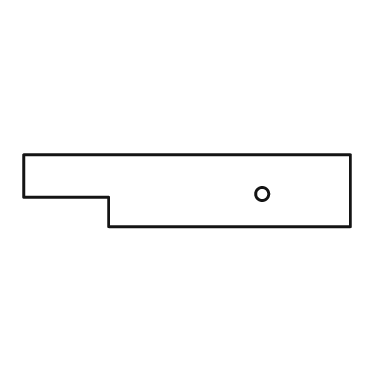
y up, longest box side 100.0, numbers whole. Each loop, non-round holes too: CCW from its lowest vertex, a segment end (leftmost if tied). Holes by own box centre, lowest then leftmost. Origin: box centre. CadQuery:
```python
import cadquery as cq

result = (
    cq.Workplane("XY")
    .moveTo(-24.0, -11.0)
    .lineTo(50.0, -11.0)
    .lineTo(50.0, 11.0)
    .lineTo(-50.0, 11.0)
    .lineTo(-50.0, -2.0)
    .lineTo(-24.0, -2.0)
    .close()
    .moveTo(23.0, -1.0)
    .circle(2.0)
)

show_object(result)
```